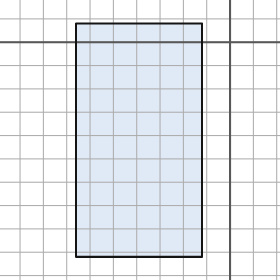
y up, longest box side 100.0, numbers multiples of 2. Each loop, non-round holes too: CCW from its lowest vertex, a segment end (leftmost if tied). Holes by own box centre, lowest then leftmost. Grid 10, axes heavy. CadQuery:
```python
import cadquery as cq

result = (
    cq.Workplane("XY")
    .moveTo(-66.0, -92.0)
    .lineTo(-12.0, -92.0)
    .lineTo(-12.0, 8.0)
    .lineTo(-66.0, 8.0)
    .close()
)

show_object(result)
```